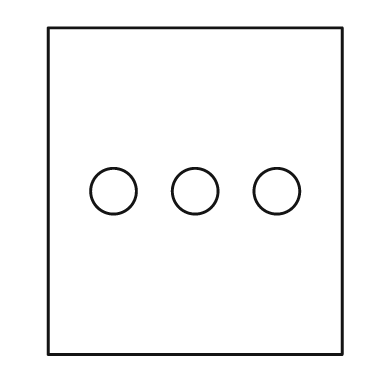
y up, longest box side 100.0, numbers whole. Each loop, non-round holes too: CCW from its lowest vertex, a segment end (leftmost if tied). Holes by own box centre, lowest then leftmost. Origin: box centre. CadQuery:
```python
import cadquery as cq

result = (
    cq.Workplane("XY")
    .moveTo(-45.0, -50.0)
    .lineTo(45.0, -50.0)
    .lineTo(45.0, 50.0)
    .lineTo(-45.0, 50.0)
    .close()
    .moveTo(-25.0, 0.0)
    .circle(7.0)
    .moveTo(0.0, 0.0)
    .circle(7.0)
    .moveTo(25.0, 0.0)
    .circle(7.0)
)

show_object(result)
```